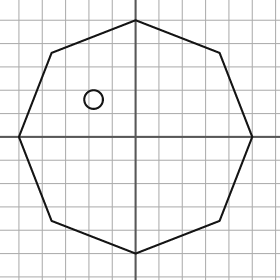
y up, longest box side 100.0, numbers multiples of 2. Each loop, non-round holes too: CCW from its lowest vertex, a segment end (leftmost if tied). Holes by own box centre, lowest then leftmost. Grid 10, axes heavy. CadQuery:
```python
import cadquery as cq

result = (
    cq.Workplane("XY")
    .moveTo(0.0, -50.0)
    .lineTo(36.0, -36.0)
    .lineTo(50.0, 0.0)
    .lineTo(36.0, 36.0)
    .lineTo(0.0, 50.0)
    .lineTo(-36.0, 36.0)
    .lineTo(-50.0, 0.0)
    .lineTo(-36.0, -36.0)
    .close()
    .moveTo(-18.0, 16.0)
    .circle(4.0)
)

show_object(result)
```